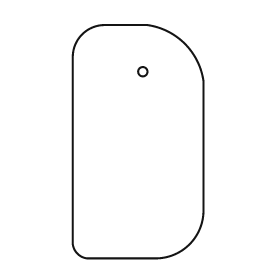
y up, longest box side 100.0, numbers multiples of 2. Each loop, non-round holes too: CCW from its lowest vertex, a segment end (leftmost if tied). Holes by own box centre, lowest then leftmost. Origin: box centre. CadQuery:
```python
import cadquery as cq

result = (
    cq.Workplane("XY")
    .moveTo(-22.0, -50.0)
    .lineTo(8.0, -50.0)
    .threePointArc((22.0, -44.0), (28.0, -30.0))
    .lineTo(28.0, 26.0)
    .threePointArc((20.0, 42.0), (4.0, 50.0))
    .lineTo(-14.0, 50.0)
    .threePointArc((-24.0, 46.0), (-28.0, 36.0))
    .lineTo(-28.0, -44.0)
    .threePointArc((-26.0, -48.0), (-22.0, -50.0))
    .close()
    .moveTo(2.0, 30.0)
    .circle(2.0)
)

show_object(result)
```